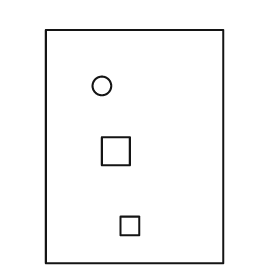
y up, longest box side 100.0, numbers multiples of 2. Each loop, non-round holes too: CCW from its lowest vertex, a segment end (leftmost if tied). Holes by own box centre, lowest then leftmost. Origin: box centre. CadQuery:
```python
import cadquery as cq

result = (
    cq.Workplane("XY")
    .moveTo(-38.0, -50.0)
    .lineTo(38.0, -50.0)
    .lineTo(38.0, 50.0)
    .lineTo(-38.0, 50.0)
    .close()
    .moveTo(-6.0, -38.0)
    .lineTo(2.0, -38.0)
    .lineTo(2.0, -30.0)
    .lineTo(-6.0, -30.0)
    .close()
    .moveTo(-14.0, -8.0)
    .lineTo(-2.0, -8.0)
    .lineTo(-2.0, 4.0)
    .lineTo(-14.0, 4.0)
    .close()
    .moveTo(-14.0, 26.0)
    .circle(4.0)
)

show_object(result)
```